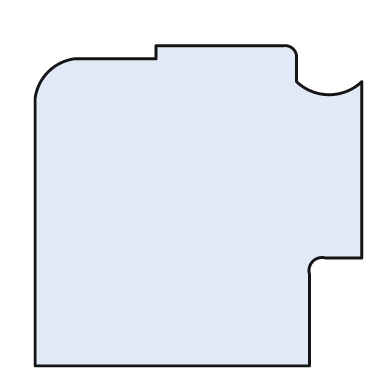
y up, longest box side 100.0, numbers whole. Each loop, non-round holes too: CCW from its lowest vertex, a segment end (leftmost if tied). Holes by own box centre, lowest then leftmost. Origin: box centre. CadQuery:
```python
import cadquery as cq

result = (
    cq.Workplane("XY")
    .moveTo(-50.0, -49.0)
    .lineTo(34.0, -49.0)
    .lineTo(34.0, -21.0)
    .threePointArc((35.0, -17.0), (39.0, -16.0))
    .lineTo(50.0, -16.0)
    .lineTo(50.0, 38.0)
    .threePointArc((40.0, 34.0), (30.0, 38.0))
    .lineTo(30.0, 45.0)
    .threePointArc((29.0, 48.0), (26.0, 49.0))
    .lineTo(-13.0, 49.0)
    .lineTo(-13.0, 45.0)
    .lineTo(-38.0, 45.0)
    .threePointArc((-46.0, 41.0), (-50.0, 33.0))
    .close()
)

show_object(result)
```